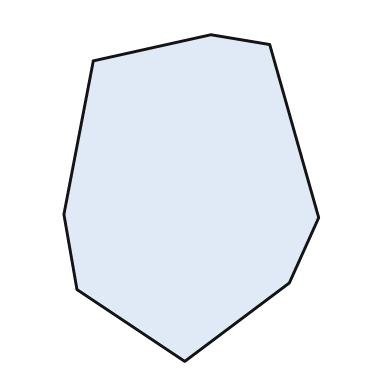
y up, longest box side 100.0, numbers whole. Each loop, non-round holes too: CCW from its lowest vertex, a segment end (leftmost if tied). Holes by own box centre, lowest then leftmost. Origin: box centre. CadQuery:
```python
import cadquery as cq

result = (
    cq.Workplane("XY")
    .moveTo(-2.0, -50.0)
    .lineTo(30.0, -26.0)
    .lineTo(39.0, -6.0)
    .lineTo(24.0, 47.0)
    .lineTo(6.0, 50.0)
    .lineTo(-30.0, 42.0)
    .lineTo(-39.0, -5.0)
    .lineTo(-35.0, -28.0)
    .close()
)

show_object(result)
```